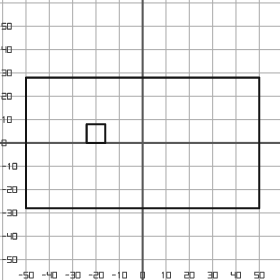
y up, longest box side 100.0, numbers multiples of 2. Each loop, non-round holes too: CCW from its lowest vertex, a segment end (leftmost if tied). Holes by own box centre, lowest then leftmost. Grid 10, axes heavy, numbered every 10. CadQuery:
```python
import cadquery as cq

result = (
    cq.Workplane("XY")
    .moveTo(-50.0, -28.0)
    .lineTo(50.0, -28.0)
    .lineTo(50.0, 28.0)
    .lineTo(-50.0, 28.0)
    .close()
    .moveTo(-24.0, 0.0)
    .lineTo(-16.0, 0.0)
    .lineTo(-16.0, 8.0)
    .lineTo(-24.0, 8.0)
    .close()
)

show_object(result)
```